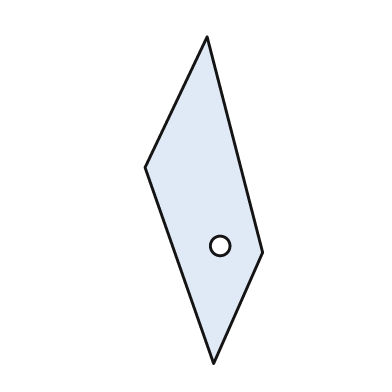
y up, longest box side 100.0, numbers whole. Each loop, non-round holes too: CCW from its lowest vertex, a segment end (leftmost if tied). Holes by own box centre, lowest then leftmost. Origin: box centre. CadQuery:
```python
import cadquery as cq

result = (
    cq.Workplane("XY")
    .moveTo(3.0, -50.0)
    .lineTo(18.0, -16.0)
    .lineTo(1.0, 50.0)
    .lineTo(-18.0, 10.0)
    .close()
    .moveTo(5.0, -14.0)
    .circle(3.0)
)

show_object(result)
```